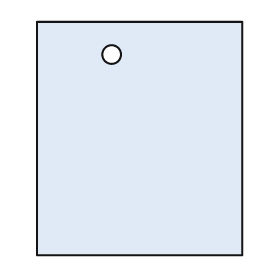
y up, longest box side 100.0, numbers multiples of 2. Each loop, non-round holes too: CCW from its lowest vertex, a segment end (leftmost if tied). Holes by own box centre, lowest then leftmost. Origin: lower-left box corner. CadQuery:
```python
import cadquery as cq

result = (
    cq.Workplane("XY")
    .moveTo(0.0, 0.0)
    .lineTo(88.0, 0.0)
    .lineTo(88.0, 100.0)
    .lineTo(0.0, 100.0)
    .close()
    .moveTo(32.0, 86.0)
    .circle(4.0)
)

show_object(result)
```